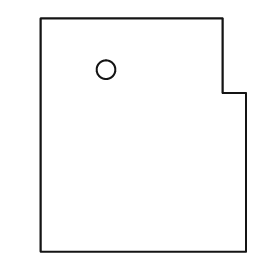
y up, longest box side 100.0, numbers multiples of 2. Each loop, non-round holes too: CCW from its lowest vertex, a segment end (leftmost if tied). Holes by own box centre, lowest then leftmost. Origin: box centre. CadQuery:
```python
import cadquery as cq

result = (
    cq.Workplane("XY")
    .moveTo(-44.0, -50.0)
    .lineTo(44.0, -50.0)
    .lineTo(44.0, 18.0)
    .lineTo(34.0, 18.0)
    .lineTo(34.0, 50.0)
    .lineTo(-44.0, 50.0)
    .close()
    .moveTo(-16.0, 28.0)
    .circle(4.0)
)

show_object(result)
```